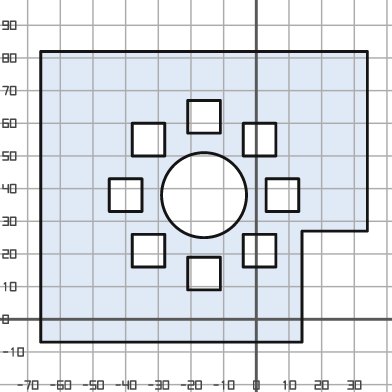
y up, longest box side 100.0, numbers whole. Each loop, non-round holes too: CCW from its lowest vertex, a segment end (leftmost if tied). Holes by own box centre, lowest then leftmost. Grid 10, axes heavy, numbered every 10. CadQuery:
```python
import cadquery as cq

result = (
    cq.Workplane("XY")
    .moveTo(-66.0, -7.0)
    .lineTo(14.0, -7.0)
    .lineTo(14.0, 27.0)
    .lineTo(34.0, 27.0)
    .lineTo(34.0, 82.0)
    .lineTo(-66.0, 82.0)
    .close()
    .moveTo(-21.0, 9.0)
    .lineTo(-11.0, 9.0)
    .lineTo(-11.0, 19.0)
    .lineTo(-21.0, 19.0)
    .close()
    .moveTo(-38.0, 16.0)
    .lineTo(-28.0, 16.0)
    .lineTo(-28.0, 26.0)
    .lineTo(-38.0, 26.0)
    .close()
    .moveTo(-4.0, 16.0)
    .lineTo(6.0, 16.0)
    .lineTo(6.0, 26.0)
    .lineTo(-4.0, 26.0)
    .close()
    .moveTo(-45.0, 33.0)
    .lineTo(-35.0, 33.0)
    .lineTo(-35.0, 43.0)
    .lineTo(-45.0, 43.0)
    .close()
    .moveTo(-16.0, 38.0)
    .circle(13.0)
    .moveTo(3.0, 33.0)
    .lineTo(13.0, 33.0)
    .lineTo(13.0, 43.0)
    .lineTo(3.0, 43.0)
    .close()
    .moveTo(-38.0, 50.0)
    .lineTo(-28.0, 50.0)
    .lineTo(-28.0, 60.0)
    .lineTo(-38.0, 60.0)
    .close()
    .moveTo(-4.0, 50.0)
    .lineTo(6.0, 50.0)
    .lineTo(6.0, 60.0)
    .lineTo(-4.0, 60.0)
    .close()
    .moveTo(-21.0, 57.0)
    .lineTo(-11.0, 57.0)
    .lineTo(-11.0, 67.0)
    .lineTo(-21.0, 67.0)
    .close()
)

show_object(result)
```